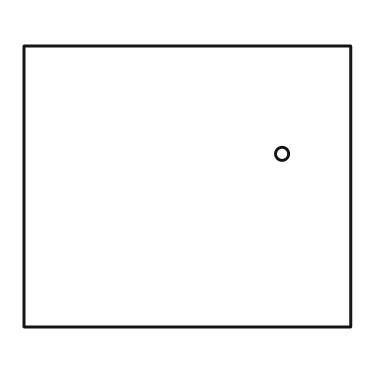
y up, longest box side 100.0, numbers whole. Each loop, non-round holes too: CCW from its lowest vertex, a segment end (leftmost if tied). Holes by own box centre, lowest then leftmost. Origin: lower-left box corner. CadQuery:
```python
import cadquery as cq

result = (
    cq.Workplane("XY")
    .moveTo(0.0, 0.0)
    .lineTo(100.0, 0.0)
    .lineTo(100.0, 86.0)
    .lineTo(0.0, 86.0)
    .close()
    .moveTo(79.0, 53.0)
    .circle(2.0)
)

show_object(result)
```